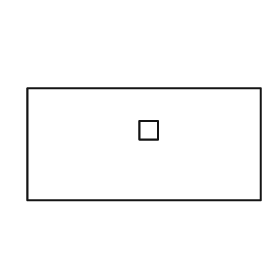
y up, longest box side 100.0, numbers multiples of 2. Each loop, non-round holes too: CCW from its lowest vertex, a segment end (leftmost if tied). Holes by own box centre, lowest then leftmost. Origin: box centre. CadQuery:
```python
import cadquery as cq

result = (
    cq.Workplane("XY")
    .moveTo(-50.0, -24.0)
    .lineTo(50.0, -24.0)
    .lineTo(50.0, 24.0)
    .lineTo(-50.0, 24.0)
    .close()
    .moveTo(-2.0, 2.0)
    .lineTo(6.0, 2.0)
    .lineTo(6.0, 10.0)
    .lineTo(-2.0, 10.0)
    .close()
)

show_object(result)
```